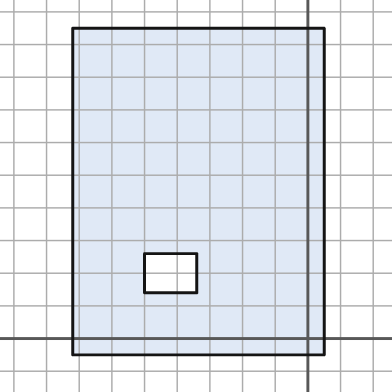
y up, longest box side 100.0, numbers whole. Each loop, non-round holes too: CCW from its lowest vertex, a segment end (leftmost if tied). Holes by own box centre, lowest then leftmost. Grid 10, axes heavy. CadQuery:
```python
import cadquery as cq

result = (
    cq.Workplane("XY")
    .moveTo(-72.0, -5.0)
    .lineTo(5.0, -5.0)
    .lineTo(5.0, 95.0)
    .lineTo(-72.0, 95.0)
    .close()
    .moveTo(-50.0, 14.0)
    .lineTo(-34.0, 14.0)
    .lineTo(-34.0, 26.0)
    .lineTo(-50.0, 26.0)
    .close()
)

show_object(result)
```